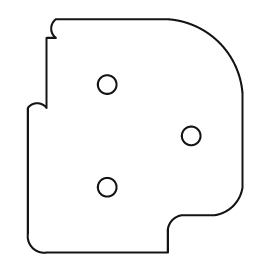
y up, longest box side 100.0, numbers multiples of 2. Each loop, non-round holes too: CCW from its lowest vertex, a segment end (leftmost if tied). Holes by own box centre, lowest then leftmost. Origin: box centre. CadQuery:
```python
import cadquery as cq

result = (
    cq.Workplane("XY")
    .moveTo(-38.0, -50.0)
    .lineTo(14.0, -50.0)
    .lineTo(14.0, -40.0)
    .threePointArc((16.0, -36.0), (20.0, -34.0))
    .lineTo(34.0, -34.0)
    .threePointArc((42.0, -30.0), (46.0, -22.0))
    .lineTo(46.0, 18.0)
    .threePointArc((36.0, 40.0), (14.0, 50.0))
    .lineTo(-34.0, 50.0)
    .threePointArc((-36.0, 46.0), (-34.0, 42.0))
    .lineTo(-38.0, 42.0)
    .lineTo(-38.0, 12.0)
    .threePointArc((-42.0, 14.0), (-46.0, 12.0))
    .lineTo(-46.0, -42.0)
    .threePointArc((-44.0, -48.0), (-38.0, -50.0))
    .close()
    .moveTo(-12.0, -22.0)
    .circle(4.0)
    .moveTo(24.0, 0.0)
    .circle(4.0)
    .moveTo(-12.0, 22.0)
    .circle(4.0)
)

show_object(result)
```